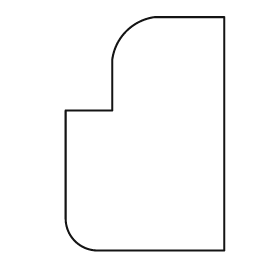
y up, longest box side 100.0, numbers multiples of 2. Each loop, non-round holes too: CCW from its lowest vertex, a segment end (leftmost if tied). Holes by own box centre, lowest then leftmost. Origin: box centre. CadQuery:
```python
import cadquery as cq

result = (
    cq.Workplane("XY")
    .moveTo(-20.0, -50.0)
    .lineTo(34.0, -50.0)
    .lineTo(34.0, 50.0)
    .lineTo(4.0, 50.0)
    .threePointArc((-8.0, 44.0), (-14.0, 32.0))
    .lineTo(-14.0, 10.0)
    .lineTo(-34.0, 10.0)
    .lineTo(-34.0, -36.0)
    .threePointArc((-30.0, -46.0), (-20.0, -50.0))
    .close()
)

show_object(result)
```